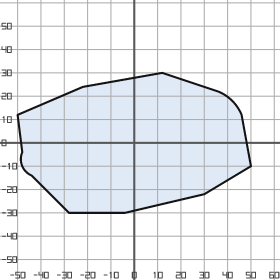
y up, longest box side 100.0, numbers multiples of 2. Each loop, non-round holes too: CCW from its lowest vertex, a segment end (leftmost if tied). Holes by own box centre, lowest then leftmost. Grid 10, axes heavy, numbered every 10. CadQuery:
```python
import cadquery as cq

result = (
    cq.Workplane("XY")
    .moveTo(-28.0, -30.0)
    .lineTo(-4.0, -30.0)
    .lineTo(30.0, -22.0)
    .lineTo(50.0, -10.0)
    .lineTo(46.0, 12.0)
    .threePointArc((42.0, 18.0), (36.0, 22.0))
    .lineTo(12.0, 30.0)
    .lineTo(-22.0, 24.0)
    .lineTo(-50.0, 12.0)
    .lineTo(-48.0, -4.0)
    .threePointArc((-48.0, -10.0), (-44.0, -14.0))
    .close()
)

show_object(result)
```